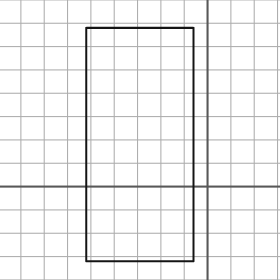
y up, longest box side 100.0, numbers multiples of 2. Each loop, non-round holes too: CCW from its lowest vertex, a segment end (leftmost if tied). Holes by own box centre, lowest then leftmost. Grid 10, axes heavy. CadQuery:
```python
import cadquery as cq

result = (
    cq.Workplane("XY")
    .moveTo(-52.0, -32.0)
    .lineTo(-6.0, -32.0)
    .lineTo(-6.0, 68.0)
    .lineTo(-52.0, 68.0)
    .close()
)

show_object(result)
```